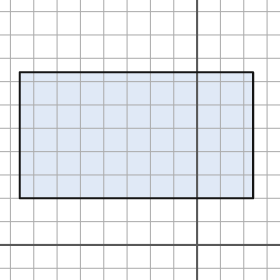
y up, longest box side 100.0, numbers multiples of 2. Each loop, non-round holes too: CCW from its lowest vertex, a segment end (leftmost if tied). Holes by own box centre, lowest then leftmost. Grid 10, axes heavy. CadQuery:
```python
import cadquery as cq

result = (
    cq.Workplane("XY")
    .moveTo(-76.0, 20.0)
    .lineTo(24.0, 20.0)
    .lineTo(24.0, 74.0)
    .lineTo(-76.0, 74.0)
    .close()
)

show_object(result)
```